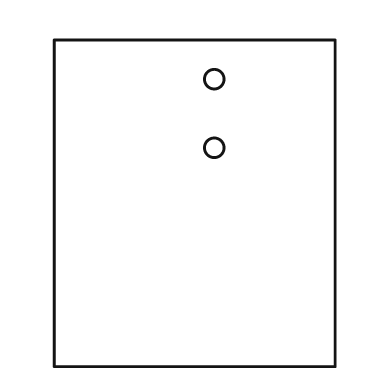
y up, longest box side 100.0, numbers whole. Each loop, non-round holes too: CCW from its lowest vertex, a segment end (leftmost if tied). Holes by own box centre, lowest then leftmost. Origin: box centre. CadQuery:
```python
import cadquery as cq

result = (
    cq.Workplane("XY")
    .moveTo(-43.0, -50.0)
    .lineTo(43.0, -50.0)
    .lineTo(43.0, 50.0)
    .lineTo(-43.0, 50.0)
    .close()
    .moveTo(6.0, 17.0)
    .circle(3.0)
    .moveTo(6.0, 38.0)
    .circle(3.0)
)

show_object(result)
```